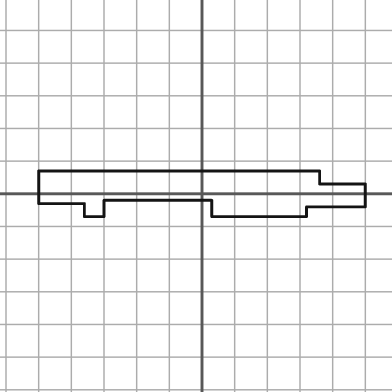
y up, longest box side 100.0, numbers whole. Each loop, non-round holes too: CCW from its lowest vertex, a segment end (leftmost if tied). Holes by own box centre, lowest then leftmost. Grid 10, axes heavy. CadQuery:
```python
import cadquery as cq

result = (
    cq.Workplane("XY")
    .moveTo(-36.0, -7.0)
    .lineTo(-30.0, -7.0)
    .lineTo(-30.0, -2.0)
    .lineTo(3.0, -2.0)
    .lineTo(3.0, -7.0)
    .lineTo(32.0, -7.0)
    .lineTo(32.0, -4.0)
    .lineTo(50.0, -4.0)
    .lineTo(50.0, 3.0)
    .lineTo(36.0, 3.0)
    .lineTo(36.0, 7.0)
    .lineTo(-50.0, 7.0)
    .lineTo(-50.0, -3.0)
    .lineTo(-36.0, -3.0)
    .close()
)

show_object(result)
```